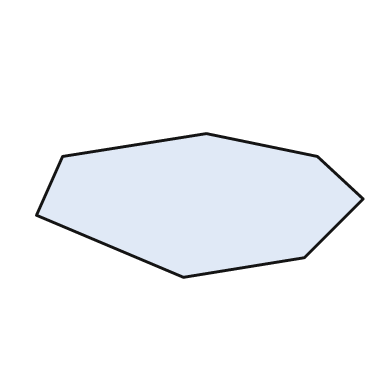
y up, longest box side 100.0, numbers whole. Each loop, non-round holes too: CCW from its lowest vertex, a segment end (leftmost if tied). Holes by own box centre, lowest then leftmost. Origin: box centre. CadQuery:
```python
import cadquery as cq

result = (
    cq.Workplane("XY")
    .moveTo(-5.0, -22.0)
    .lineTo(32.0, -16.0)
    .lineTo(50.0, 2.0)
    .lineTo(36.0, 15.0)
    .lineTo(2.0, 22.0)
    .lineTo(-42.0, 15.0)
    .lineTo(-50.0, -3.0)
    .close()
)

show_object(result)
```